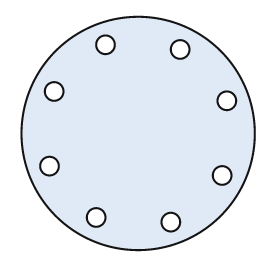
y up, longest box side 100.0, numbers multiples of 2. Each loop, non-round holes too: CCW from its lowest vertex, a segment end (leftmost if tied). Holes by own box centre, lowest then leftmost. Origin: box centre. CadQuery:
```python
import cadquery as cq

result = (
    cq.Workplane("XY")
    .moveTo(0.0, 0.0)
    .circle(50.0)
    .moveTo(14.0, -38.0)
    .circle(4.0)
    .moveTo(-18.0, -36.0)
    .circle(4.0)
    .moveTo(36.0, -18.0)
    .circle(4.0)
    .moveTo(-38.0, -14.0)
    .circle(4.0)
    .moveTo(38.0, 14.0)
    .circle(4.0)
    .moveTo(-36.0, 18.0)
    .circle(4.0)
    .moveTo(18.0, 36.0)
    .circle(4.0)
    .moveTo(-14.0, 38.0)
    .circle(4.0)
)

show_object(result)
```